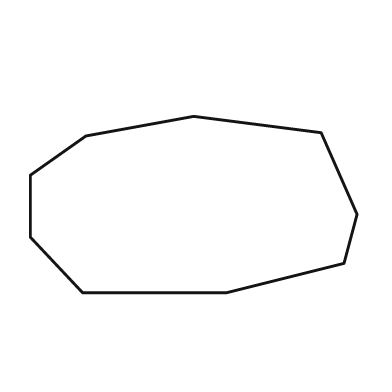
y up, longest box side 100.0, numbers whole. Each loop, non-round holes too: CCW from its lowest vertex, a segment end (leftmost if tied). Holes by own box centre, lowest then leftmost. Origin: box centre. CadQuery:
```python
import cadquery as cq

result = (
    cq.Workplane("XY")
    .moveTo(-34.0, -27.0)
    .lineTo(10.0, -27.0)
    .lineTo(46.0, -18.0)
    .lineTo(50.0, -3.0)
    .lineTo(39.0, 22.0)
    .lineTo(0.0, 27.0)
    .lineTo(-33.0, 21.0)
    .lineTo(-50.0, 9.0)
    .lineTo(-50.0, -10.0)
    .close()
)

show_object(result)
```